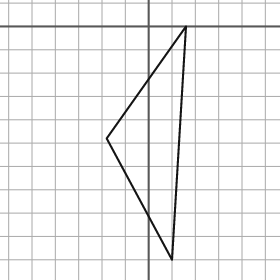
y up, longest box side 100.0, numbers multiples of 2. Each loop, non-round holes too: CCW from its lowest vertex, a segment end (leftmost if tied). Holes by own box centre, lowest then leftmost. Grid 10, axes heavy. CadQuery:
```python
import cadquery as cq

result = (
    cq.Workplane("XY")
    .moveTo(10.0, -100.0)
    .lineTo(16.0, 0.0)
    .lineTo(-18.0, -48.0)
    .close()
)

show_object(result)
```